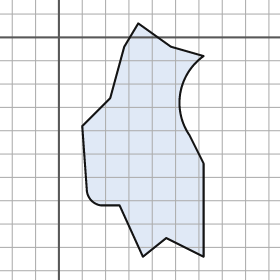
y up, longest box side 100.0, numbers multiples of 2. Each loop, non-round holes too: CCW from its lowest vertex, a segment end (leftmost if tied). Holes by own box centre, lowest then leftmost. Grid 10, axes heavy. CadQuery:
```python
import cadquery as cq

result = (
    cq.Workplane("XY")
    .moveTo(36.0, -94.0)
    .lineTo(46.0, -86.0)
    .lineTo(62.0, -94.0)
    .lineTo(62.0, -54.0)
    .lineTo(56.0, -42.0)
    .threePointArc((52.0, -24.0), (62.0, -8.0))
    .lineTo(48.0, -4.0)
    .lineTo(34.0, 6.0)
    .lineTo(28.0, -4.0)
    .lineTo(22.0, -26.0)
    .lineTo(10.0, -38.0)
    .lineTo(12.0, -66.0)
    .threePointArc((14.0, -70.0), (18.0, -72.0))
    .lineTo(26.0, -72.0)
    .close()
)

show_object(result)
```